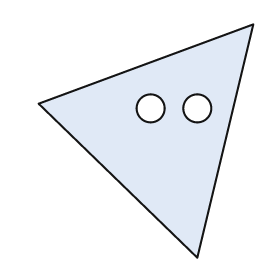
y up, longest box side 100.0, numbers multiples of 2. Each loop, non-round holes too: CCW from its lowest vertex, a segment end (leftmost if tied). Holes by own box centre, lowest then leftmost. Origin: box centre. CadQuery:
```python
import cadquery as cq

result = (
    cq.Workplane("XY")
    .moveTo(22.0, -50.0)
    .lineTo(46.0, 50.0)
    .lineTo(-46.0, 16.0)
    .close()
    .moveTo(2.0, 14.0)
    .circle(6.0)
    .moveTo(22.0, 14.0)
    .circle(6.0)
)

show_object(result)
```